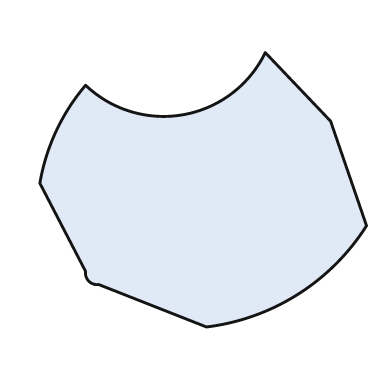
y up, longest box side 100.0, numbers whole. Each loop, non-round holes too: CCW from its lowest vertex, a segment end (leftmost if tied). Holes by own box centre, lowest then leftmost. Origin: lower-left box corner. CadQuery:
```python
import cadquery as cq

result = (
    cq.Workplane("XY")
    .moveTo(51.0, 0.0)
    .threePointArc((79.0, 10.0), (100.0, 31.0))
    .lineTo(89.0, 63.0)
    .lineTo(69.0, 84.0)
    .threePointArc((44.0, 65.0), (14.0, 74.0))
    .threePointArc((5.0, 60.0), (0.0, 44.0))
    .lineTo(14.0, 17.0)
    .threePointArc((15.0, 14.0), (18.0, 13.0))
    .close()
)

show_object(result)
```